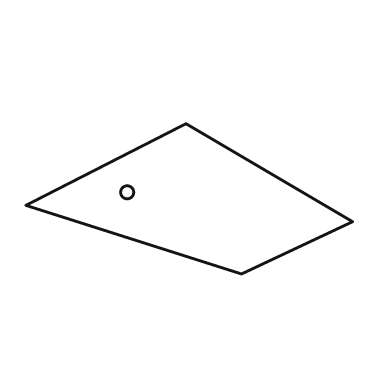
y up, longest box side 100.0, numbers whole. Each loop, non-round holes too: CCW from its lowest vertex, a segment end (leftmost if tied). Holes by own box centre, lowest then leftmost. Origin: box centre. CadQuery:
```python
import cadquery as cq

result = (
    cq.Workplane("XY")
    .moveTo(16.0, -23.0)
    .lineTo(50.0, -7.0)
    .lineTo(-1.0, 23.0)
    .lineTo(-50.0, -2.0)
    .close()
    .moveTo(-19.0, 2.0)
    .circle(2.0)
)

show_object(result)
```